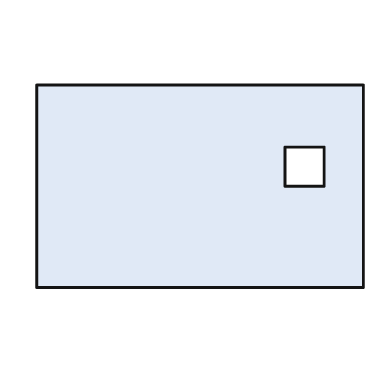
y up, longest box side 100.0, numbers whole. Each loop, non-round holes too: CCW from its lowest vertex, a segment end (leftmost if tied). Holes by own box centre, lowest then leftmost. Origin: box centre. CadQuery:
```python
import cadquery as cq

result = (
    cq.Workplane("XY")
    .moveTo(-50.0, -31.0)
    .lineTo(50.0, -31.0)
    .lineTo(50.0, 31.0)
    .lineTo(-50.0, 31.0)
    .close()
    .moveTo(26.0, 0.0)
    .lineTo(38.0, 0.0)
    .lineTo(38.0, 12.0)
    .lineTo(26.0, 12.0)
    .close()
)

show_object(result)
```